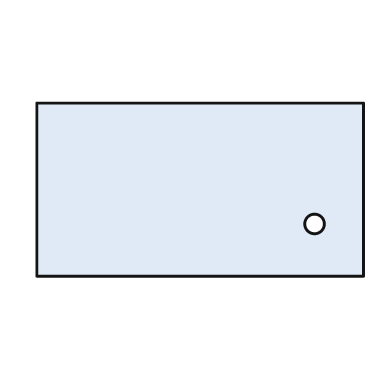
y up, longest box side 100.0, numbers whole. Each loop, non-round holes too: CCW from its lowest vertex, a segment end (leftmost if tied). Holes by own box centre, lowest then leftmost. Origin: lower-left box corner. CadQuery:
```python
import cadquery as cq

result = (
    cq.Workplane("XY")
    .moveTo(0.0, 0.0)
    .lineTo(100.0, 0.0)
    .lineTo(100.0, 53.0)
    .lineTo(0.0, 53.0)
    .close()
    .moveTo(85.0, 16.0)
    .circle(3.0)
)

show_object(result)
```